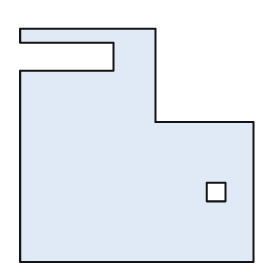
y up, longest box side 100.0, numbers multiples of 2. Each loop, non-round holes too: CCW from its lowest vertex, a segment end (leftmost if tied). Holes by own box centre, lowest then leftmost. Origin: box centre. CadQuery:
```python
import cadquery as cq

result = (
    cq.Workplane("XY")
    .moveTo(-50.0, -50.0)
    .lineTo(50.0, -50.0)
    .lineTo(50.0, 10.0)
    .lineTo(8.0, 10.0)
    .lineTo(8.0, 50.0)
    .lineTo(-50.0, 50.0)
    .lineTo(-50.0, 44.0)
    .lineTo(-10.0, 44.0)
    .lineTo(-10.0, 32.0)
    .lineTo(-50.0, 32.0)
    .close()
    .moveTo(30.0, -24.0)
    .lineTo(38.0, -24.0)
    .lineTo(38.0, -16.0)
    .lineTo(30.0, -16.0)
    .close()
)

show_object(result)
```